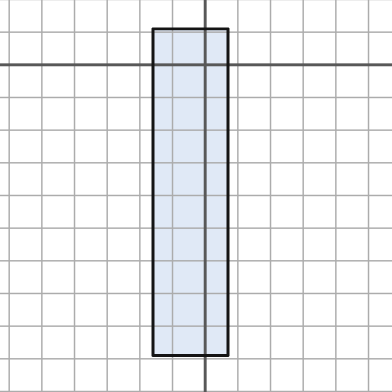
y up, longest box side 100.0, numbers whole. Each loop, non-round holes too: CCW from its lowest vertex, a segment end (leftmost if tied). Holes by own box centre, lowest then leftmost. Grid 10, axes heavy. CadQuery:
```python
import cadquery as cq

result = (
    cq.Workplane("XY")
    .moveTo(-16.0, -89.0)
    .lineTo(7.0, -89.0)
    .lineTo(7.0, 11.0)
    .lineTo(-16.0, 11.0)
    .close()
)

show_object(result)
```